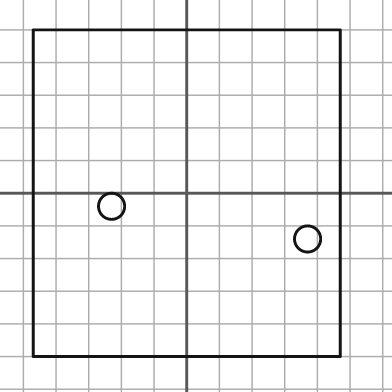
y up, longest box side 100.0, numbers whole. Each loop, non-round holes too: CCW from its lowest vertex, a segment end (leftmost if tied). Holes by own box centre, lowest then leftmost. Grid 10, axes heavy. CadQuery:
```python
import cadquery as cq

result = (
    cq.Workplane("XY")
    .moveTo(-47.0, -50.0)
    .lineTo(47.0, -50.0)
    .lineTo(47.0, 50.0)
    .lineTo(-47.0, 50.0)
    .close()
    .moveTo(37.0, -14.0)
    .circle(4.0)
    .moveTo(-23.0, -4.0)
    .circle(4.0)
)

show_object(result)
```